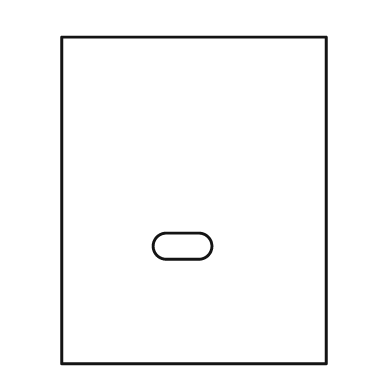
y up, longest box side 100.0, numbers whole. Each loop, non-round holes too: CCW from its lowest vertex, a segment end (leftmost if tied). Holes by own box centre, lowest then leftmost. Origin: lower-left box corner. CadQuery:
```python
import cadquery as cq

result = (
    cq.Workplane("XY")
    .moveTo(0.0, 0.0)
    .lineTo(81.0, 0.0)
    .lineTo(81.0, 100.0)
    .lineTo(0.0, 100.0)
    .close()
    .moveTo(32.0, 32.0)
    .lineTo(42.0, 32.0)
    .threePointArc((46.0, 36.0), (42.0, 40.0))
    .lineTo(32.0, 40.0)
    .threePointArc((28.0, 36.0), (32.0, 32.0))
    .close()
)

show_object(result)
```